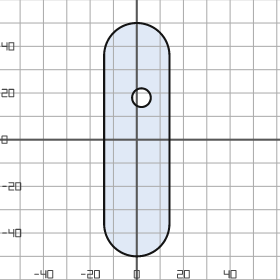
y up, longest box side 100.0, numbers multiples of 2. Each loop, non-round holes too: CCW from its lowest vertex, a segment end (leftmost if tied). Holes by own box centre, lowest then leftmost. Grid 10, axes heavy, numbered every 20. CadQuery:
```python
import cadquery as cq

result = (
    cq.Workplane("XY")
    .moveTo(-14.0, -36.0)
    .threePointArc((0.0, -50.0), (14.0, -36.0))
    .lineTo(14.0, 36.0)
    .threePointArc((0.0, 50.0), (-14.0, 36.0))
    .close()
    .moveTo(2.0, 18.0)
    .circle(4.0)
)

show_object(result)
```